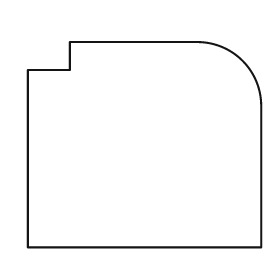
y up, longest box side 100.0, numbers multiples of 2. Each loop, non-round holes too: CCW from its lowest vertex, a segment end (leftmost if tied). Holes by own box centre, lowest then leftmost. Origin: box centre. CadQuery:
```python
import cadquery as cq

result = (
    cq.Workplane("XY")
    .moveTo(-50.0, -44.0)
    .lineTo(50.0, -44.0)
    .lineTo(50.0, 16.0)
    .threePointArc((42.0, 36.0), (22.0, 44.0))
    .lineTo(-32.0, 44.0)
    .lineTo(-32.0, 32.0)
    .lineTo(-50.0, 32.0)
    .close()
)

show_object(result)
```